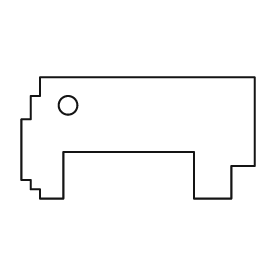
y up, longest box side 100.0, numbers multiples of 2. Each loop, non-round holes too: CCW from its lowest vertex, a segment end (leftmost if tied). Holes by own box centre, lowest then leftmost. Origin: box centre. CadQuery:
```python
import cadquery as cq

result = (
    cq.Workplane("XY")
    .moveTo(-42.0, -26.0)
    .lineTo(-32.0, -26.0)
    .lineTo(-32.0, -6.0)
    .lineTo(24.0, -6.0)
    .lineTo(24.0, -26.0)
    .lineTo(40.0, -26.0)
    .lineTo(40.0, -12.0)
    .lineTo(50.0, -12.0)
    .lineTo(50.0, 26.0)
    .lineTo(-42.0, 26.0)
    .lineTo(-42.0, 18.0)
    .lineTo(-46.0, 18.0)
    .lineTo(-46.0, 8.0)
    .lineTo(-50.0, 8.0)
    .lineTo(-50.0, -18.0)
    .lineTo(-46.0, -18.0)
    .lineTo(-46.0, -22.0)
    .lineTo(-42.0, -22.0)
    .close()
    .moveTo(-30.0, 14.0)
    .circle(4.0)
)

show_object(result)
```